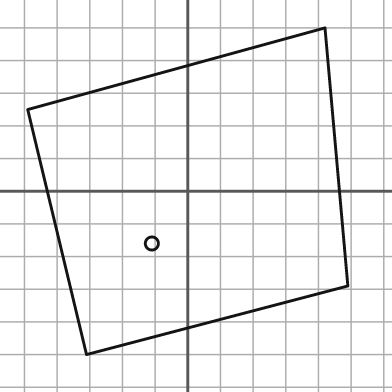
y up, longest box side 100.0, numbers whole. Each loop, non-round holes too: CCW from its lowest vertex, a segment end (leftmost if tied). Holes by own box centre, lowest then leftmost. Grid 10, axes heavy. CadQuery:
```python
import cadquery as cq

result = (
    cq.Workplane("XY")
    .moveTo(-31.0, -50.0)
    .lineTo(49.0, -29.0)
    .lineTo(42.0, 50.0)
    .lineTo(-49.0, 25.0)
    .close()
    .moveTo(-11.0, -16.0)
    .circle(2.0)
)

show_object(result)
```